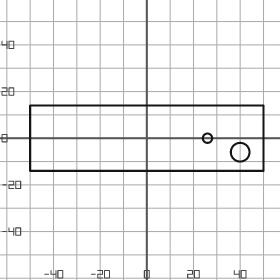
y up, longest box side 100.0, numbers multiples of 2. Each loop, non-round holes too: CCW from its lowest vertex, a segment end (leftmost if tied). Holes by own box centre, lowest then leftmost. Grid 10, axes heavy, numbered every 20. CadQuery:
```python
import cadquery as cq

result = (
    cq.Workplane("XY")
    .moveTo(-50.0, -14.0)
    .lineTo(50.0, -14.0)
    .lineTo(50.0, 14.0)
    .lineTo(-50.0, 14.0)
    .close()
    .moveTo(40.0, -6.0)
    .circle(4.0)
    .moveTo(26.0, 0.0)
    .circle(2.0)
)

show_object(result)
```